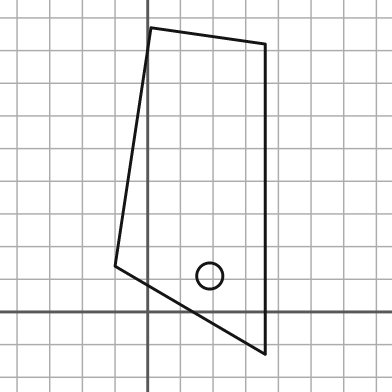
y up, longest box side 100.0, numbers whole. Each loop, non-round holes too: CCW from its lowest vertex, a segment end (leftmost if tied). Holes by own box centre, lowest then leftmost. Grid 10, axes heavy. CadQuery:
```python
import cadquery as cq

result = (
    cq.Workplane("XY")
    .moveTo(36.0, -13.0)
    .lineTo(36.0, 82.0)
    .lineTo(1.0, 87.0)
    .lineTo(-10.0, 14.0)
    .close()
    .moveTo(19.0, 11.0)
    .circle(4.0)
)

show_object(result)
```